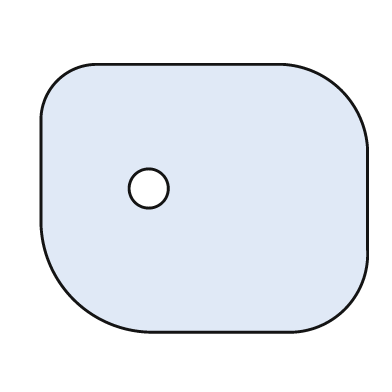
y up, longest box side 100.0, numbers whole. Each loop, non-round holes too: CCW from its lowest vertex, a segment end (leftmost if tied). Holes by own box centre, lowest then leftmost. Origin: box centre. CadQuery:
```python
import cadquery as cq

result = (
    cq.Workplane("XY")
    .moveTo(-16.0, -41.0)
    .lineTo(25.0, -41.0)
    .threePointArc((43.0, -34.0), (50.0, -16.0))
    .lineTo(50.0, 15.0)
    .threePointArc((42.0, 33.0), (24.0, 41.0))
    .lineTo(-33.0, 41.0)
    .threePointArc((-45.0, 36.0), (-50.0, 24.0))
    .lineTo(-50.0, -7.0)
    .threePointArc((-40.0, -31.0), (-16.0, -41.0))
    .close()
    .moveTo(-17.0, 3.0)
    .circle(6.0)
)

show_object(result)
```